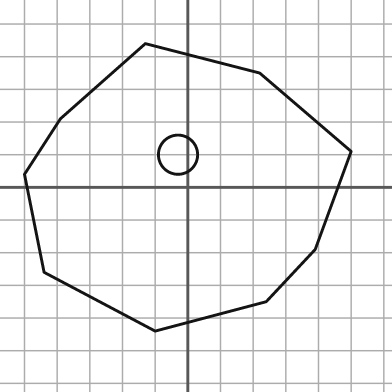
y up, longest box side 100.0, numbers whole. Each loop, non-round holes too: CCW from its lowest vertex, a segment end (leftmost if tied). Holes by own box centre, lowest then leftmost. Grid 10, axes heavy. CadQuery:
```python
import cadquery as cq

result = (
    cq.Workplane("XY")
    .moveTo(-10.0, -44.0)
    .lineTo(24.0, -35.0)
    .lineTo(39.0, -19.0)
    .lineTo(50.0, 11.0)
    .lineTo(22.0, 35.0)
    .lineTo(-13.0, 44.0)
    .lineTo(-39.0, 21.0)
    .lineTo(-50.0, 4.0)
    .lineTo(-44.0, -26.0)
    .close()
    .moveTo(-3.0, 10.0)
    .circle(6.0)
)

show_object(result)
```